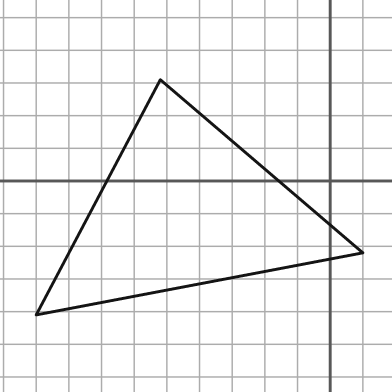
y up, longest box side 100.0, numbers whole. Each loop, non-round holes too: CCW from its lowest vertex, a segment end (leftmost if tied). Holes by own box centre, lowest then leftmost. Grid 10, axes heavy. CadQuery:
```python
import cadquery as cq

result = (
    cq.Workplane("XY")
    .moveTo(-90.0, -41.0)
    .lineTo(10.0, -22.0)
    .lineTo(-52.0, 31.0)
    .close()
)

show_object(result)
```